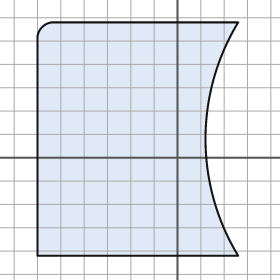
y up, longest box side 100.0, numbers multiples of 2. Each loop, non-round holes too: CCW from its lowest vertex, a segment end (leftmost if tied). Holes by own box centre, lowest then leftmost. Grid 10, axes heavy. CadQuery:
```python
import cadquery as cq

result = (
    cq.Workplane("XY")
    .moveTo(-60.0, -42.0)
    .lineTo(26.0, -42.0)
    .threePointArc((12.0, 8.0), (26.0, 58.0))
    .lineTo(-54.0, 58.0)
    .threePointArc((-58.0, 56.0), (-60.0, 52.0))
    .close()
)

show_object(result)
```